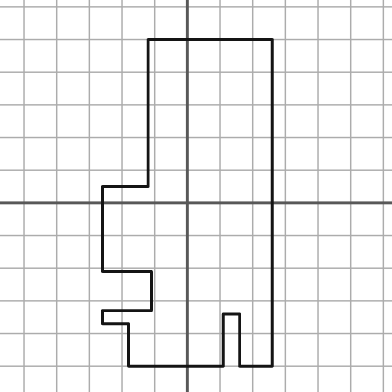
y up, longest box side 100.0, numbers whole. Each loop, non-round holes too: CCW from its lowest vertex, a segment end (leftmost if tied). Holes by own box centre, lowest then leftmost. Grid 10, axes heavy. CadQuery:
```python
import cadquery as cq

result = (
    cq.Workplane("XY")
    .moveTo(-18.0, -50.0)
    .lineTo(11.0, -50.0)
    .lineTo(11.0, -34.0)
    .lineTo(16.0, -34.0)
    .lineTo(16.0, -50.0)
    .lineTo(26.0, -50.0)
    .lineTo(26.0, 50.0)
    .lineTo(-12.0, 50.0)
    .lineTo(-12.0, 5.0)
    .lineTo(-26.0, 5.0)
    .lineTo(-26.0, -21.0)
    .lineTo(-11.0, -21.0)
    .lineTo(-11.0, -33.0)
    .lineTo(-26.0, -33.0)
    .lineTo(-26.0, -37.0)
    .lineTo(-18.0, -37.0)
    .close()
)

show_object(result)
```